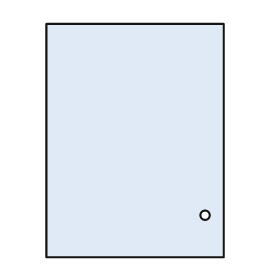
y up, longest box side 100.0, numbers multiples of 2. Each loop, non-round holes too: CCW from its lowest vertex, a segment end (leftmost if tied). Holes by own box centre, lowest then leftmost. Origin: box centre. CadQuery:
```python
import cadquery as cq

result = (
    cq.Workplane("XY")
    .moveTo(-38.0, -50.0)
    .lineTo(38.0, -50.0)
    .lineTo(38.0, 50.0)
    .lineTo(-38.0, 50.0)
    .close()
    .moveTo(30.0, -32.0)
    .circle(2.0)
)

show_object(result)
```